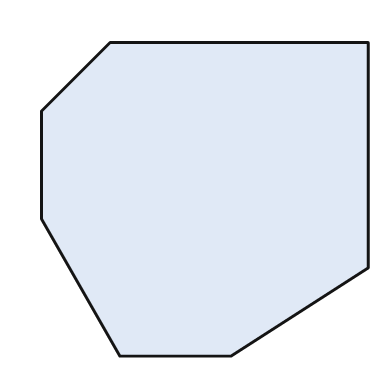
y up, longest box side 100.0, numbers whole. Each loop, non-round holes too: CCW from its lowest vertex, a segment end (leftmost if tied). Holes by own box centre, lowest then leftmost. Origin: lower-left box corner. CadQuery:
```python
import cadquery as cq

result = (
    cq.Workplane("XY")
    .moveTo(24.0, 0.0)
    .lineTo(58.0, 0.0)
    .lineTo(100.0, 27.0)
    .lineTo(100.0, 96.0)
    .lineTo(21.0, 96.0)
    .lineTo(0.0, 75.0)
    .lineTo(0.0, 42.0)
    .close()
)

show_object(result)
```